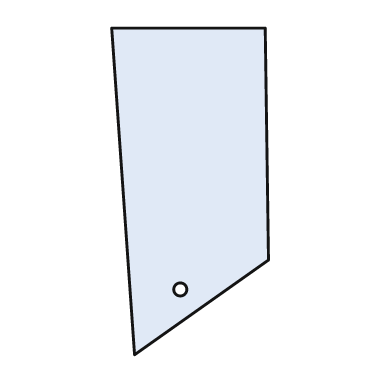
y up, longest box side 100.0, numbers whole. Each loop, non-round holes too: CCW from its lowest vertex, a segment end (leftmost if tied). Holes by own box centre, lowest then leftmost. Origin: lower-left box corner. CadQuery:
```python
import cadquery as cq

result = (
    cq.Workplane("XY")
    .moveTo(7.0, 0.0)
    .lineTo(48.0, 29.0)
    .lineTo(47.0, 100.0)
    .lineTo(0.0, 100.0)
    .close()
    .moveTo(21.0, 20.0)
    .circle(2.0)
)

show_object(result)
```